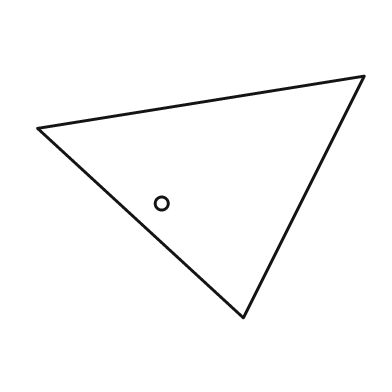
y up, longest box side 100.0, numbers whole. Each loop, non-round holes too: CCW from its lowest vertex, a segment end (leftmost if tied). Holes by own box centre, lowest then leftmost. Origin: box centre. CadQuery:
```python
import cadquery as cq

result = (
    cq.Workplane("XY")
    .moveTo(13.0, -37.0)
    .lineTo(50.0, 37.0)
    .lineTo(-50.0, 21.0)
    .close()
    .moveTo(-12.0, -2.0)
    .circle(2.0)
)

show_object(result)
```